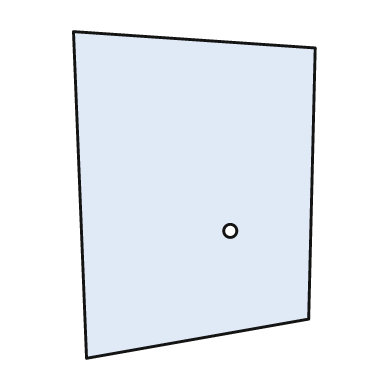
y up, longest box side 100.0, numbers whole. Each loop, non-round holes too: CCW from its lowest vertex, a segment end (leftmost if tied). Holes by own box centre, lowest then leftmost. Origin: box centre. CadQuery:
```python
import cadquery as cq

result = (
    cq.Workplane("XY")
    .moveTo(-33.0, -50.0)
    .lineTo(35.0, -38.0)
    .lineTo(37.0, 45.0)
    .lineTo(-37.0, 50.0)
    .close()
    .moveTo(11.0, -11.0)
    .circle(2.0)
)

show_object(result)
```